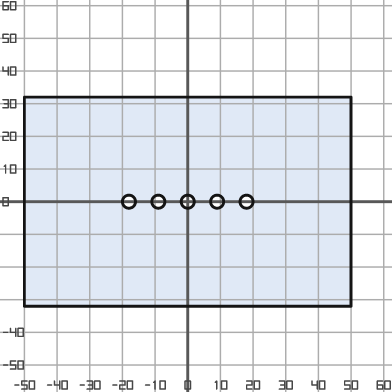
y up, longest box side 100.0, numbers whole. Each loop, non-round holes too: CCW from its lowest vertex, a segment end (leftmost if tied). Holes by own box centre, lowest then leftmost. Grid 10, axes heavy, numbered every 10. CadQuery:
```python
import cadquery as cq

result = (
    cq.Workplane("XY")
    .moveTo(-50.0, -32.0)
    .lineTo(50.0, -32.0)
    .lineTo(50.0, 32.0)
    .lineTo(-50.0, 32.0)
    .close()
    .moveTo(-18.0, 0.0)
    .circle(2.0)
    .moveTo(-9.0, 0.0)
    .circle(2.0)
    .moveTo(0.0, 0.0)
    .circle(2.0)
    .moveTo(9.0, 0.0)
    .circle(2.0)
    .moveTo(18.0, 0.0)
    .circle(2.0)
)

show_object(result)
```